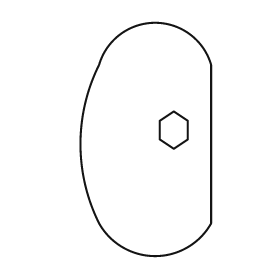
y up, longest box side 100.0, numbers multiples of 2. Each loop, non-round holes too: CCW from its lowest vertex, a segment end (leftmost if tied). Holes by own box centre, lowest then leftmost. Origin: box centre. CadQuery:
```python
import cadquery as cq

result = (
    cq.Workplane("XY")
    .moveTo(-20.0, -36.0)
    .threePointArc((4.0, -50.0), (28.0, -36.0))
    .lineTo(28.0, 32.0)
    .threePointArc((4.0, 50.0), (-20.0, 32.0))
    .threePointArc((-28.0, -2.0), (-20.0, -36.0))
    .close()
    .moveTo(12.0, -4.0)
    .lineTo(18.0, 0.0)
    .lineTo(18.0, 8.0)
    .lineTo(12.0, 12.0)
    .lineTo(6.0, 8.0)
    .lineTo(6.0, 0.0)
    .close()
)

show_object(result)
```